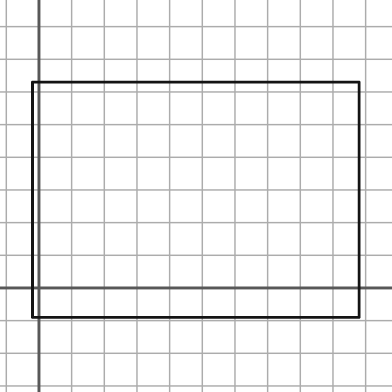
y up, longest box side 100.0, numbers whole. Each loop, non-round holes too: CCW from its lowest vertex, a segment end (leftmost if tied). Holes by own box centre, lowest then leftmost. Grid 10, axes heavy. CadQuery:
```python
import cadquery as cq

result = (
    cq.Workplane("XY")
    .moveTo(-2.0, -9.0)
    .lineTo(98.0, -9.0)
    .lineTo(98.0, 63.0)
    .lineTo(-2.0, 63.0)
    .close()
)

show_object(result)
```